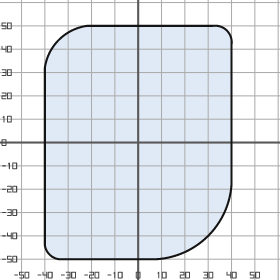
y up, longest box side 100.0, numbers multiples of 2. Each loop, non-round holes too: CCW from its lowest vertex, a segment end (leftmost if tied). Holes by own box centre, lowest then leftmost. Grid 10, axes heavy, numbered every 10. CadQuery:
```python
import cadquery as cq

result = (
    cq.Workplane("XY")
    .moveTo(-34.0, -50.0)
    .lineTo(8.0, -50.0)
    .threePointArc((30.0, -40.0), (40.0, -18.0))
    .lineTo(40.0, 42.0)
    .threePointArc((38.0, 48.0), (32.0, 50.0))
    .lineTo(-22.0, 50.0)
    .threePointArc((-34.0, 44.0), (-40.0, 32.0))
    .lineTo(-40.0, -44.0)
    .threePointArc((-38.0, -48.0), (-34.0, -50.0))
    .close()
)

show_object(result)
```